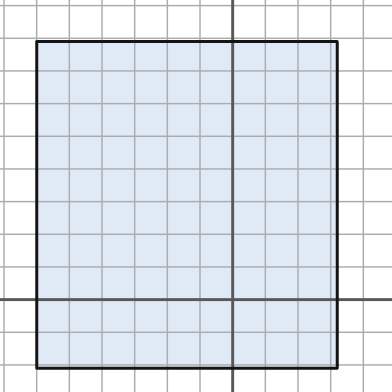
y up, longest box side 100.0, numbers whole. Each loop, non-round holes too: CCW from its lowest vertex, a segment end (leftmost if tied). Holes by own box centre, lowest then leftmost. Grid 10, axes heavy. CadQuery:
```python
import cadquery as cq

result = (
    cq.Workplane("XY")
    .moveTo(-60.0, -21.0)
    .lineTo(32.0, -21.0)
    .lineTo(32.0, 79.0)
    .lineTo(-60.0, 79.0)
    .close()
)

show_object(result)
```